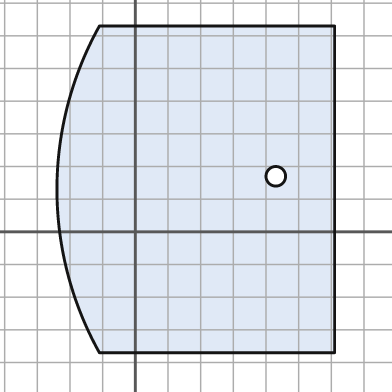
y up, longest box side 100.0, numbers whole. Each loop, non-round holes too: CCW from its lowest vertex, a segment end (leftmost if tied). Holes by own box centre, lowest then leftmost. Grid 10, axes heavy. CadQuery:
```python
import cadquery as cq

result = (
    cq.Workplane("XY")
    .moveTo(-11.0, -37.0)
    .lineTo(61.0, -37.0)
    .lineTo(61.0, 63.0)
    .lineTo(-11.0, 63.0)
    .threePointArc((-24.0, 13.0), (-11.0, -37.0))
    .close()
    .moveTo(43.0, 17.0)
    .circle(3.0)
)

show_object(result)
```